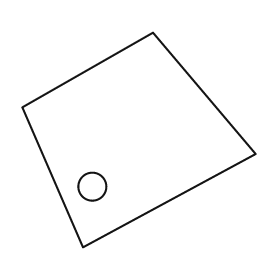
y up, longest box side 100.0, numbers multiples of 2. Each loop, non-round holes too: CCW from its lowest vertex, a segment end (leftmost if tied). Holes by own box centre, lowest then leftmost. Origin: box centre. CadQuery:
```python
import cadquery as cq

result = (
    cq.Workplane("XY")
    .moveTo(-24.0, -46.0)
    .lineTo(50.0, -6.0)
    .lineTo(6.0, 46.0)
    .lineTo(-50.0, 14.0)
    .close()
    .moveTo(-20.0, -20.0)
    .circle(6.0)
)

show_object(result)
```